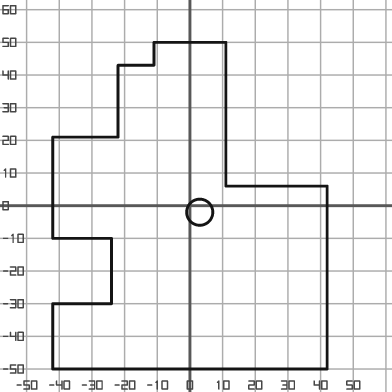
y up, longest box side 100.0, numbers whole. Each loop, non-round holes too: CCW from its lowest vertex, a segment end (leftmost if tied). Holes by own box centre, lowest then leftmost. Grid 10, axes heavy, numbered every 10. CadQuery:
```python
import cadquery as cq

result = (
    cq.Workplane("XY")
    .moveTo(-42.0, -50.0)
    .lineTo(42.0, -50.0)
    .lineTo(42.0, 6.0)
    .lineTo(11.0, 6.0)
    .lineTo(11.0, 50.0)
    .lineTo(-11.0, 50.0)
    .lineTo(-11.0, 43.0)
    .lineTo(-22.0, 43.0)
    .lineTo(-22.0, 21.0)
    .lineTo(-42.0, 21.0)
    .lineTo(-42.0, -10.0)
    .lineTo(-24.0, -10.0)
    .lineTo(-24.0, -30.0)
    .lineTo(-42.0, -30.0)
    .close()
    .moveTo(3.0, -2.0)
    .circle(4.0)
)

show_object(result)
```